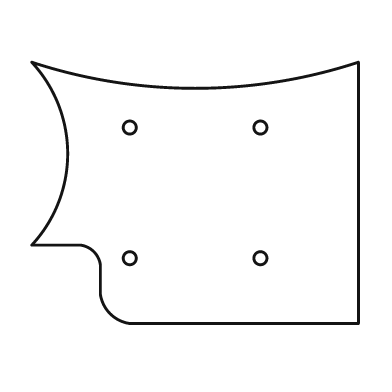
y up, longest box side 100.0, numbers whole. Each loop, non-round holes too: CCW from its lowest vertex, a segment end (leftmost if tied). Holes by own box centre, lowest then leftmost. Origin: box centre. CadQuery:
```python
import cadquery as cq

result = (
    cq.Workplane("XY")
    .moveTo(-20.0, -40.0)
    .lineTo(50.0, -40.0)
    .lineTo(50.0, 40.0)
    .threePointArc((0.0, 32.0), (-50.0, 40.0))
    .threePointArc((-39.0, 12.0), (-50.0, -16.0))
    .lineTo(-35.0, -16.0)
    .threePointArc((-31.0, -18.0), (-29.0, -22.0))
    .lineTo(-29.0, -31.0)
    .threePointArc((-26.0, -37.0), (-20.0, -40.0))
    .close()
    .moveTo(-20.0, -20.0)
    .circle(2.0)
    .moveTo(20.0, -20.0)
    .circle(2.0)
    .moveTo(-20.0, 20.0)
    .circle(2.0)
    .moveTo(20.0, 20.0)
    .circle(2.0)
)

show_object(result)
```